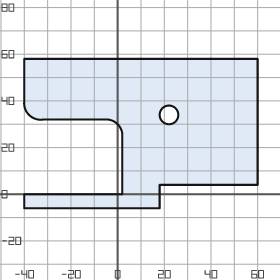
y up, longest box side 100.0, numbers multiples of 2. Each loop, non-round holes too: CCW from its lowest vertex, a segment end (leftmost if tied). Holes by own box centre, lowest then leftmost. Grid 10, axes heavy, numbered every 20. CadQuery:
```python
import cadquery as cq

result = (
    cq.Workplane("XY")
    .moveTo(-40.0, -6.0)
    .lineTo(18.0, -6.0)
    .lineTo(18.0, 4.0)
    .lineTo(60.0, 4.0)
    .lineTo(60.0, 58.0)
    .lineTo(-40.0, 58.0)
    .lineTo(-40.0, 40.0)
    .threePointArc((-38.0, 34.0), (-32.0, 32.0))
    .lineTo(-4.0, 32.0)
    .threePointArc((0.0, 30.0), (2.0, 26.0))
    .lineTo(2.0, 0.0)
    .lineTo(-40.0, 0.0)
    .close()
    .moveTo(22.0, 34.0)
    .circle(4.0)
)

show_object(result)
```